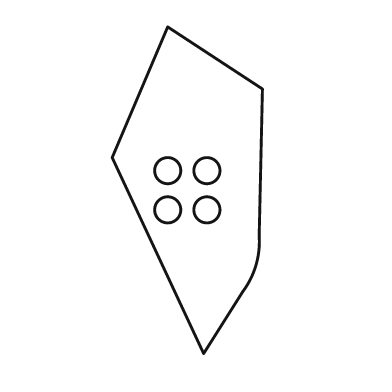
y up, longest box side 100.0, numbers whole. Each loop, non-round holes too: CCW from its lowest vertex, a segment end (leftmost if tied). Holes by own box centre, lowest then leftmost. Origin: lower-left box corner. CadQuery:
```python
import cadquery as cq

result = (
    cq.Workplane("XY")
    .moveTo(28.0, 0.0)
    .lineTo(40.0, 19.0)
    .threePointArc((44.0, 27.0), (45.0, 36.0))
    .lineTo(46.0, 81.0)
    .lineTo(17.0, 100.0)
    .lineTo(0.0, 60.0)
    .close()
    .moveTo(17.0, 44.0)
    .circle(4.0)
    .moveTo(29.0, 44.0)
    .circle(4.0)
    .moveTo(17.0, 56.0)
    .circle(4.0)
    .moveTo(29.0, 56.0)
    .circle(4.0)
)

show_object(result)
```